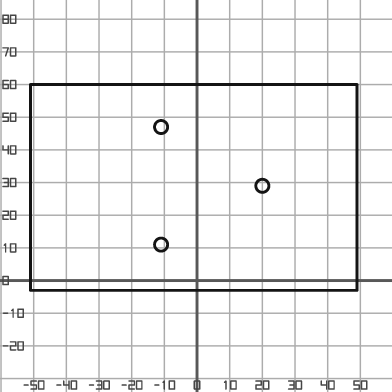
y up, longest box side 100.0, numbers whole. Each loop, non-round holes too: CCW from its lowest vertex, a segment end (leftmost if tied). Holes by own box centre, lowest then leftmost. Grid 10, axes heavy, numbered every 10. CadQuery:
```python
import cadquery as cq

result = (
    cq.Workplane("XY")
    .moveTo(-51.0, -3.0)
    .lineTo(49.0, -3.0)
    .lineTo(49.0, 60.0)
    .lineTo(-51.0, 60.0)
    .close()
    .moveTo(-11.0, 11.0)
    .circle(2.0)
    .moveTo(20.0, 29.0)
    .circle(2.0)
    .moveTo(-11.0, 47.0)
    .circle(2.0)
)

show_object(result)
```